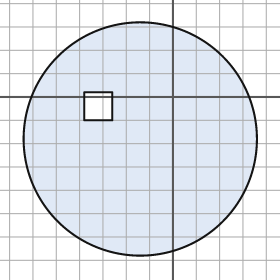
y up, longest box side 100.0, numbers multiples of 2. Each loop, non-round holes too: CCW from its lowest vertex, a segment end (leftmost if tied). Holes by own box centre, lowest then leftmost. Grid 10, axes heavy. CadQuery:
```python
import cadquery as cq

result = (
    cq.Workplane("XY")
    .moveTo(-14.0, -18.0)
    .circle(50.0)
    .moveTo(-38.0, -10.0)
    .lineTo(-26.0, -10.0)
    .lineTo(-26.0, 2.0)
    .lineTo(-38.0, 2.0)
    .close()
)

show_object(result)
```